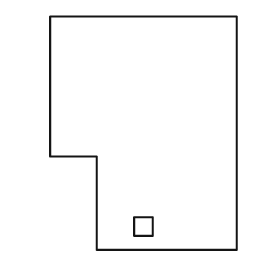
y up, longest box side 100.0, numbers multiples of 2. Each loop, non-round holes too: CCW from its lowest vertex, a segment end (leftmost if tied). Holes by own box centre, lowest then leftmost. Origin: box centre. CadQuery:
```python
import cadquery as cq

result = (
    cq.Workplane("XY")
    .moveTo(-20.0, -50.0)
    .lineTo(40.0, -50.0)
    .lineTo(40.0, 50.0)
    .lineTo(-40.0, 50.0)
    .lineTo(-40.0, -10.0)
    .lineTo(-20.0, -10.0)
    .close()
    .moveTo(-4.0, -44.0)
    .lineTo(4.0, -44.0)
    .lineTo(4.0, -36.0)
    .lineTo(-4.0, -36.0)
    .close()
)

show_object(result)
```